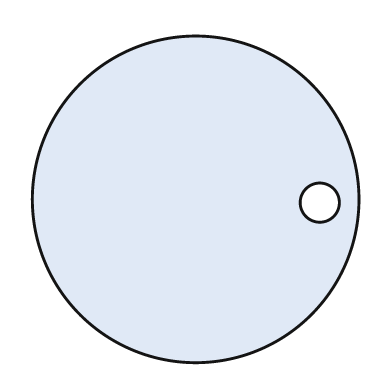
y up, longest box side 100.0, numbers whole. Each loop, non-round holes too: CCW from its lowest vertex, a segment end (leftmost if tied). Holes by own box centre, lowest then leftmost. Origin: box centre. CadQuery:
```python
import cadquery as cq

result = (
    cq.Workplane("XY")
    .moveTo(0.0, 0.0)
    .circle(50.0)
    .moveTo(38.0, -1.0)
    .circle(6.0)
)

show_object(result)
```